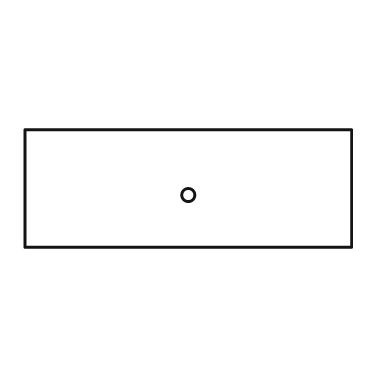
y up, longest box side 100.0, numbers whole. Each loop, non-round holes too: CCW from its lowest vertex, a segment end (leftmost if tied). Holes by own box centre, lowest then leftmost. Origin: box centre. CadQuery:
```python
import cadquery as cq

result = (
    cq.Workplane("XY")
    .moveTo(-50.0, -18.0)
    .lineTo(50.0, -18.0)
    .lineTo(50.0, 18.0)
    .lineTo(-50.0, 18.0)
    .close()
    .moveTo(0.0, -2.0)
    .circle(2.0)
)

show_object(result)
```